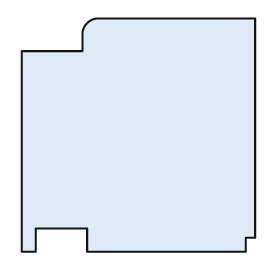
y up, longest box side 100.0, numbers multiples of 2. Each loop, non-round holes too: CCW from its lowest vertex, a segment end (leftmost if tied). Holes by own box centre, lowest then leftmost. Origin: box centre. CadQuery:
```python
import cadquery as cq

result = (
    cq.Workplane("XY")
    .moveTo(-50.0, -50.0)
    .lineTo(-44.0, -50.0)
    .lineTo(-44.0, -40.0)
    .lineTo(-22.0, -40.0)
    .lineTo(-22.0, -50.0)
    .lineTo(46.0, -50.0)
    .lineTo(46.0, -44.0)
    .lineTo(50.0, -44.0)
    .lineTo(50.0, 50.0)
    .lineTo(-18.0, 50.0)
    .threePointArc((-22.0, 48.0), (-24.0, 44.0))
    .lineTo(-24.0, 36.0)
    .lineTo(-50.0, 36.0)
    .close()
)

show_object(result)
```